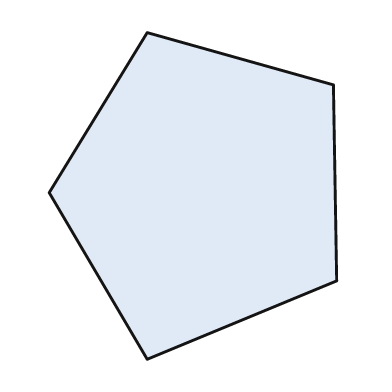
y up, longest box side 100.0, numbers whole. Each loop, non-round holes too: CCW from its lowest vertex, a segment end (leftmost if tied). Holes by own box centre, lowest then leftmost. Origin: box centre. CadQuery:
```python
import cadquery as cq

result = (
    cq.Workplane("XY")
    .moveTo(-14.0, -50.0)
    .lineTo(44.0, -26.0)
    .lineTo(43.0, 34.0)
    .lineTo(-14.0, 50.0)
    .lineTo(-44.0, 1.0)
    .close()
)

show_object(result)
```